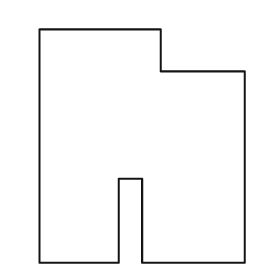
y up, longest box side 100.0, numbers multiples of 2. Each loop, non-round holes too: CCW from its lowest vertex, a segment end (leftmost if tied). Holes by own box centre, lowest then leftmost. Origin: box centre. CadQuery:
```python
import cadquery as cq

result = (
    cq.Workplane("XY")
    .moveTo(-44.0, -50.0)
    .lineTo(-10.0, -50.0)
    .lineTo(-10.0, -14.0)
    .lineTo(0.0, -14.0)
    .lineTo(0.0, -50.0)
    .lineTo(44.0, -50.0)
    .lineTo(44.0, 32.0)
    .lineTo(8.0, 32.0)
    .lineTo(8.0, 50.0)
    .lineTo(-44.0, 50.0)
    .close()
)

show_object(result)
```